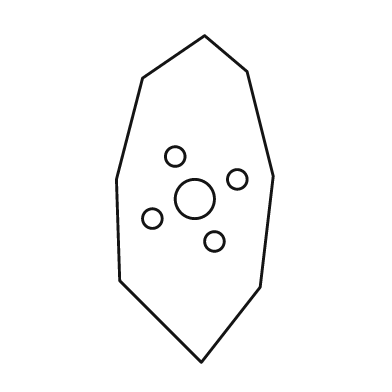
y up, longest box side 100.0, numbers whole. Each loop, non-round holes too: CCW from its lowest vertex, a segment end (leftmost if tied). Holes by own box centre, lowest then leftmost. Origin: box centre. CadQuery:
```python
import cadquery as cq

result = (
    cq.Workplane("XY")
    .moveTo(2.0, -50.0)
    .lineTo(20.0, -27.0)
    .lineTo(24.0, 7.0)
    .lineTo(16.0, 39.0)
    .lineTo(3.0, 50.0)
    .lineTo(-16.0, 37.0)
    .lineTo(-24.0, 6.0)
    .lineTo(-23.0, -25.0)
    .close()
    .moveTo(6.0, -13.0)
    .circle(3.0)
    .moveTo(-13.0, -6.0)
    .circle(3.0)
    .moveTo(0.0, 0.0)
    .circle(6.0)
    .moveTo(13.0, 6.0)
    .circle(3.0)
    .moveTo(-6.0, 13.0)
    .circle(3.0)
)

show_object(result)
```